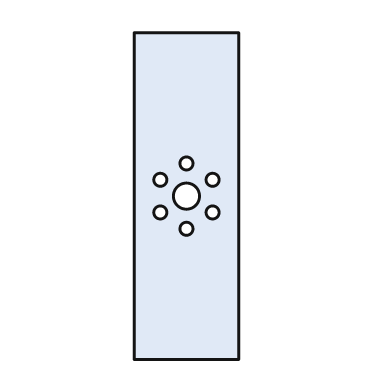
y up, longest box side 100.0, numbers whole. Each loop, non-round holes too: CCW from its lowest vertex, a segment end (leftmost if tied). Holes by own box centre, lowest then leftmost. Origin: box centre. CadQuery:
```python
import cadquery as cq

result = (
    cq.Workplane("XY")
    .moveTo(-16.0, -50.0)
    .lineTo(16.0, -50.0)
    .lineTo(16.0, 50.0)
    .lineTo(-16.0, 50.0)
    .close()
    .moveTo(0.0, -10.0)
    .circle(2.0)
    .moveTo(-8.0, -5.0)
    .circle(2.0)
    .moveTo(8.0, -5.0)
    .circle(2.0)
    .moveTo(0.0, 0.0)
    .circle(4.0)
    .moveTo(-8.0, 5.0)
    .circle(2.0)
    .moveTo(8.0, 5.0)
    .circle(2.0)
    .moveTo(0.0, 10.0)
    .circle(2.0)
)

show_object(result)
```